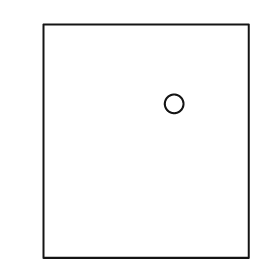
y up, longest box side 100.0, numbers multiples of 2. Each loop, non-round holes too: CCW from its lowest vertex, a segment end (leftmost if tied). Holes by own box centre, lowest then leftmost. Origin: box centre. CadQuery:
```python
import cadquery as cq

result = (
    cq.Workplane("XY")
    .moveTo(-44.0, -50.0)
    .lineTo(44.0, -50.0)
    .lineTo(44.0, 50.0)
    .lineTo(-44.0, 50.0)
    .close()
    .moveTo(12.0, 16.0)
    .circle(4.0)
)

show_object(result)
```